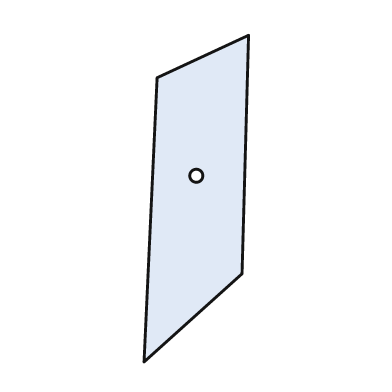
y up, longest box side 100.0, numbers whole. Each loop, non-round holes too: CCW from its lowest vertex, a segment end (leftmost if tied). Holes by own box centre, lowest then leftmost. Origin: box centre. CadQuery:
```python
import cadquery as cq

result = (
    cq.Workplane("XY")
    .moveTo(-16.0, -50.0)
    .lineTo(14.0, -23.0)
    .lineTo(16.0, 50.0)
    .lineTo(-12.0, 37.0)
    .close()
    .moveTo(0.0, 7.0)
    .circle(2.0)
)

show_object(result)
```